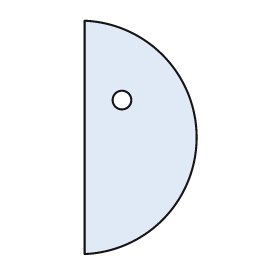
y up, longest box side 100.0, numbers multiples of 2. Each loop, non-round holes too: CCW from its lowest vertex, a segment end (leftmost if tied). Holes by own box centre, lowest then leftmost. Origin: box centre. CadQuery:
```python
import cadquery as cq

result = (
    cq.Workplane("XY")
    .moveTo(-24.0, -50.0)
    .threePointArc((24.0, 0.0), (-24.0, 50.0))
    .close()
    .moveTo(-8.0, 16.0)
    .circle(4.0)
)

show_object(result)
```